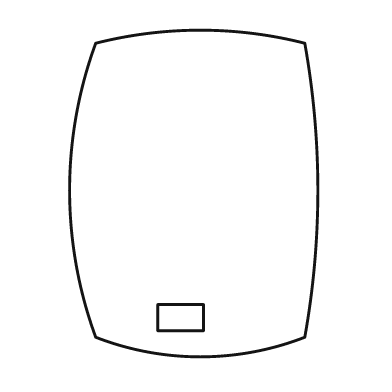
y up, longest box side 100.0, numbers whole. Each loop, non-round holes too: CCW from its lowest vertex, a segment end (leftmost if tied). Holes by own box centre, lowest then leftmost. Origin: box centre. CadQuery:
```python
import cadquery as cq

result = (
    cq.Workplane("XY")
    .moveTo(-30.0, -44.0)
    .threePointArc((2.0, -50.0), (34.0, -44.0))
    .threePointArc((38.0, 1.0), (34.0, 46.0))
    .threePointArc((2.0, 50.0), (-30.0, 46.0))
    .threePointArc((-38.0, 1.0), (-30.0, -44.0))
    .close()
    .moveTo(-11.0, -42.0)
    .lineTo(3.0, -42.0)
    .lineTo(3.0, -34.0)
    .lineTo(-11.0, -34.0)
    .close()
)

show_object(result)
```